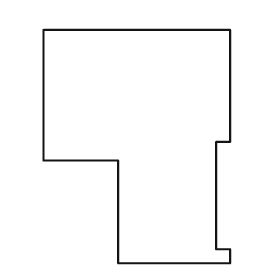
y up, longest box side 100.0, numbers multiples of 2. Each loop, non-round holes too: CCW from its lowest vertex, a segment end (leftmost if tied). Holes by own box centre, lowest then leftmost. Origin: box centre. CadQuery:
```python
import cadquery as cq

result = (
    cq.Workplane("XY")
    .moveTo(-8.0, -50.0)
    .lineTo(40.0, -50.0)
    .lineTo(40.0, -44.0)
    .lineTo(34.0, -44.0)
    .lineTo(34.0, 2.0)
    .lineTo(40.0, 2.0)
    .lineTo(40.0, 50.0)
    .lineTo(-40.0, 50.0)
    .lineTo(-40.0, -6.0)
    .lineTo(-8.0, -6.0)
    .close()
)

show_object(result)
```